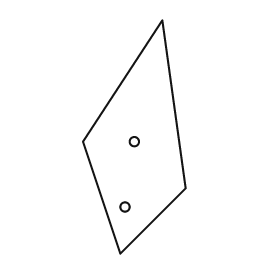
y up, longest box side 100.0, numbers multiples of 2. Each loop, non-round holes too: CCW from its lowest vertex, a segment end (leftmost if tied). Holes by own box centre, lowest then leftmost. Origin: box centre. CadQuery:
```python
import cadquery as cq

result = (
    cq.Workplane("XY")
    .moveTo(-6.0, -50.0)
    .lineTo(22.0, -22.0)
    .lineTo(12.0, 50.0)
    .lineTo(-22.0, -2.0)
    .close()
    .moveTo(-4.0, -30.0)
    .circle(2.0)
    .moveTo(0.0, -2.0)
    .circle(2.0)
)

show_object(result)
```